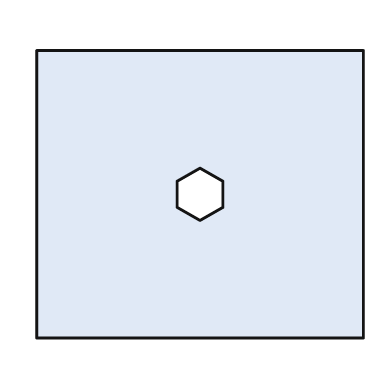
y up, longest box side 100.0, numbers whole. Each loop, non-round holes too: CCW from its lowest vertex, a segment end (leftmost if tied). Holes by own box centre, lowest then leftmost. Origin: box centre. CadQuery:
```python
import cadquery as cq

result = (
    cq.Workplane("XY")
    .moveTo(-50.0, -44.0)
    .lineTo(50.0, -44.0)
    .lineTo(50.0, 44.0)
    .lineTo(-50.0, 44.0)
    .close()
    .moveTo(0.0, -8.0)
    .lineTo(7.0, -4.0)
    .lineTo(7.0, 4.0)
    .lineTo(0.0, 8.0)
    .lineTo(-7.0, 4.0)
    .lineTo(-7.0, -4.0)
    .close()
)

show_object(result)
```